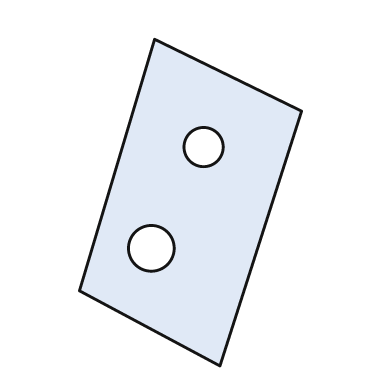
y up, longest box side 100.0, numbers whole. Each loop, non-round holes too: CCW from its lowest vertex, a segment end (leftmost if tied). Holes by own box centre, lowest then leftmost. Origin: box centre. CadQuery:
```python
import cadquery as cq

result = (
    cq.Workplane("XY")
    .moveTo(9.0, -50.0)
    .lineTo(34.0, 28.0)
    .lineTo(-11.0, 50.0)
    .lineTo(-34.0, -27.0)
    .close()
    .moveTo(-12.0, -14.0)
    .circle(7.0)
    .moveTo(4.0, 17.0)
    .circle(6.0)
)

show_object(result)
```